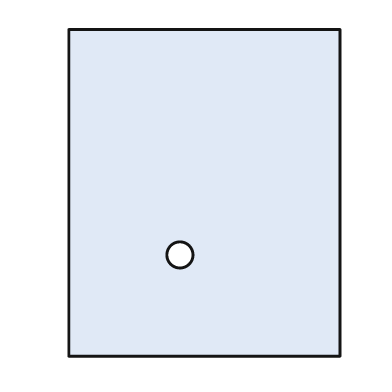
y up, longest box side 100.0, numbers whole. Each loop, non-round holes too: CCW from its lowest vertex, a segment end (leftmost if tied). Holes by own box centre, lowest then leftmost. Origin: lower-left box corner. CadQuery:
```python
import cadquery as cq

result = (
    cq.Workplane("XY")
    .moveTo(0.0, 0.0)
    .lineTo(83.0, 0.0)
    .lineTo(83.0, 100.0)
    .lineTo(0.0, 100.0)
    .close()
    .moveTo(34.0, 31.0)
    .circle(4.0)
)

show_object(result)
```